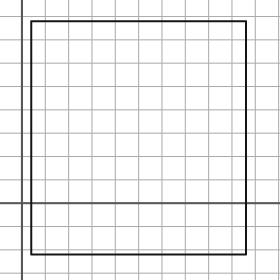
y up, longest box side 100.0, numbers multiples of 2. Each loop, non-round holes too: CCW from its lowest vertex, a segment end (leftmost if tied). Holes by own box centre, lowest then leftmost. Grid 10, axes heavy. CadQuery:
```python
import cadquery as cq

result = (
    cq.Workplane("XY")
    .moveTo(4.0, -22.0)
    .lineTo(96.0, -22.0)
    .lineTo(96.0, 78.0)
    .lineTo(4.0, 78.0)
    .close()
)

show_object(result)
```